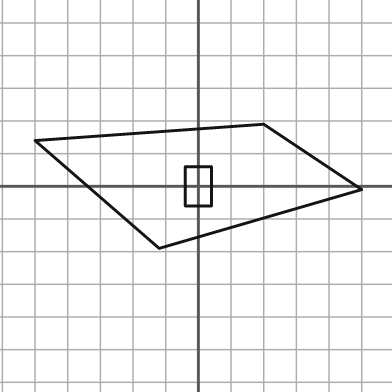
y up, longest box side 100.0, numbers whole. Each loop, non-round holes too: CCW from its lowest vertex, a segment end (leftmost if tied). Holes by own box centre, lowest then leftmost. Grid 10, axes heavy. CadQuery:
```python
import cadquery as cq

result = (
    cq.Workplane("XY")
    .moveTo(-12.0, -19.0)
    .lineTo(50.0, -1.0)
    .lineTo(20.0, 19.0)
    .lineTo(-50.0, 14.0)
    .close()
    .moveTo(-4.0, -6.0)
    .lineTo(4.0, -6.0)
    .lineTo(4.0, 6.0)
    .lineTo(-4.0, 6.0)
    .close()
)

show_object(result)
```